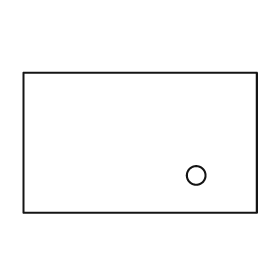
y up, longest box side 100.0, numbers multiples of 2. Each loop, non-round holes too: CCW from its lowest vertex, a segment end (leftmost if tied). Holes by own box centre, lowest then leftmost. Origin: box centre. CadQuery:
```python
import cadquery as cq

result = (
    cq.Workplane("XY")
    .moveTo(-50.0, -30.0)
    .lineTo(50.0, -30.0)
    .lineTo(50.0, 30.0)
    .lineTo(-50.0, 30.0)
    .close()
    .moveTo(24.0, -14.0)
    .circle(4.0)
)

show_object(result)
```